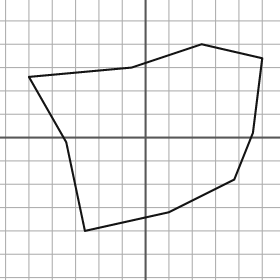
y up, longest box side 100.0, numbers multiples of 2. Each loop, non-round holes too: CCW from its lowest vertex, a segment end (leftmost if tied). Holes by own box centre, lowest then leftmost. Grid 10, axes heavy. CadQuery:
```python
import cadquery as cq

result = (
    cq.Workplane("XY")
    .moveTo(-26.0, -40.0)
    .lineTo(10.0, -32.0)
    .lineTo(38.0, -18.0)
    .lineTo(46.0, 2.0)
    .lineTo(50.0, 34.0)
    .lineTo(24.0, 40.0)
    .lineTo(-6.0, 30.0)
    .lineTo(-50.0, 26.0)
    .lineTo(-34.0, -2.0)
    .close()
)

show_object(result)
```